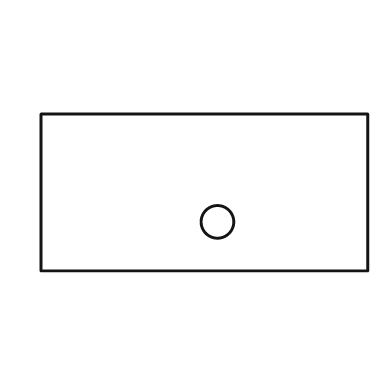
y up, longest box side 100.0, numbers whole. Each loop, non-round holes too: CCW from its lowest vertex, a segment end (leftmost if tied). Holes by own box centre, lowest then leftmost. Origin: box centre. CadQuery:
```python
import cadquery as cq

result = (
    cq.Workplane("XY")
    .moveTo(-50.0, -24.0)
    .lineTo(50.0, -24.0)
    .lineTo(50.0, 24.0)
    .lineTo(-50.0, 24.0)
    .close()
    .moveTo(4.0, -9.0)
    .circle(5.0)
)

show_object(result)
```